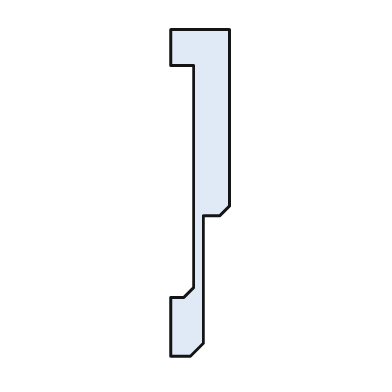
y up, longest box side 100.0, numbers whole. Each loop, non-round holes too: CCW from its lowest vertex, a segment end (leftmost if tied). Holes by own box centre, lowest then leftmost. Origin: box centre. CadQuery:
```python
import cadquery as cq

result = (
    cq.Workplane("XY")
    .moveTo(-9.0, -50.0)
    .lineTo(-3.0, -50.0)
    .lineTo(1.0, -46.0)
    .lineTo(1.0, -7.0)
    .lineTo(6.0, -7.0)
    .lineTo(9.0, -4.0)
    .lineTo(9.0, 50.0)
    .lineTo(-9.0, 50.0)
    .lineTo(-9.0, 39.0)
    .lineTo(-2.0, 39.0)
    .lineTo(-2.0, -29.0)
    .lineTo(-5.0, -32.0)
    .lineTo(-9.0, -32.0)
    .close()
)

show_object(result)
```